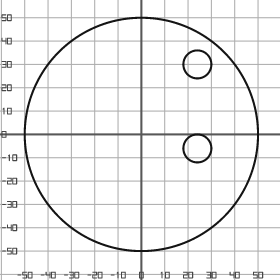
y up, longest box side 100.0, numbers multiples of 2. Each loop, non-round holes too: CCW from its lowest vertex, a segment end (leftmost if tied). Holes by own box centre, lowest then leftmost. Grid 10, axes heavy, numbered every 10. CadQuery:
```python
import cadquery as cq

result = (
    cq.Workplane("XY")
    .moveTo(0.0, 0.0)
    .circle(50.0)
    .moveTo(24.0, -6.0)
    .circle(6.0)
    .moveTo(24.0, 30.0)
    .circle(6.0)
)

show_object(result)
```